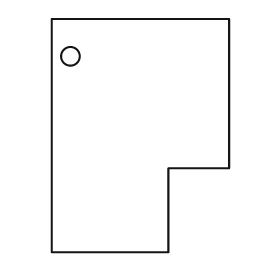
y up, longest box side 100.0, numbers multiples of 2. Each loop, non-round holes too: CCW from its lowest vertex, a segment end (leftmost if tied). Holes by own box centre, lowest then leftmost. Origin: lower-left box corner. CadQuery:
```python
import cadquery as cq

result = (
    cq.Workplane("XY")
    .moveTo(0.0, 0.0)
    .lineTo(50.0, 0.0)
    .lineTo(50.0, 36.0)
    .lineTo(76.0, 36.0)
    .lineTo(76.0, 100.0)
    .lineTo(0.0, 100.0)
    .close()
    .moveTo(8.0, 84.0)
    .circle(4.0)
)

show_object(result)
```